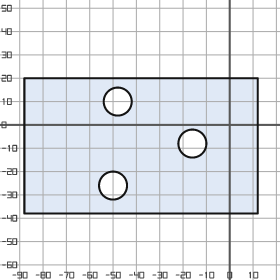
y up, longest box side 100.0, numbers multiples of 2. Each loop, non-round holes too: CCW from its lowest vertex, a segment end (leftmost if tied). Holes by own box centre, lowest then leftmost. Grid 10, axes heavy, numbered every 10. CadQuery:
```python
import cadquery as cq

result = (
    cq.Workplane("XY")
    .moveTo(-88.0, -38.0)
    .lineTo(12.0, -38.0)
    .lineTo(12.0, 20.0)
    .lineTo(-88.0, 20.0)
    .close()
    .moveTo(-50.0, -26.0)
    .circle(6.0)
    .moveTo(-16.0, -8.0)
    .circle(6.0)
    .moveTo(-48.0, 10.0)
    .circle(6.0)
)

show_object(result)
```